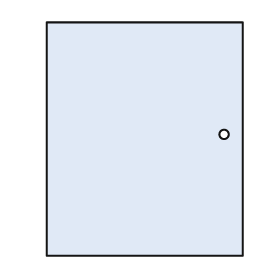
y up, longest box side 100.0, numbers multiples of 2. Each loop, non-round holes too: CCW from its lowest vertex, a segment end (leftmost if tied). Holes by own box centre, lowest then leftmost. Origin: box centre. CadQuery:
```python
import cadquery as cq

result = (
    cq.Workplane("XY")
    .moveTo(-42.0, -50.0)
    .lineTo(42.0, -50.0)
    .lineTo(42.0, 50.0)
    .lineTo(-42.0, 50.0)
    .close()
    .moveTo(34.0, 2.0)
    .circle(2.0)
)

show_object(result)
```